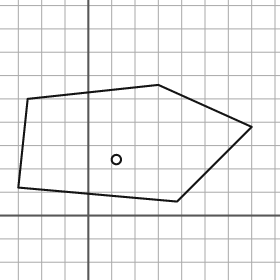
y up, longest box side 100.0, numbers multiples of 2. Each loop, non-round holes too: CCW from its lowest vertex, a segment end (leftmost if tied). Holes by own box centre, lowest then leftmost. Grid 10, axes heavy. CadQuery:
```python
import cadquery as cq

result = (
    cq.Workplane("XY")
    .moveTo(38.0, 6.0)
    .lineTo(70.0, 38.0)
    .lineTo(30.0, 56.0)
    .lineTo(-26.0, 50.0)
    .lineTo(-30.0, 12.0)
    .close()
    .moveTo(12.0, 24.0)
    .circle(2.0)
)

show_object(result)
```